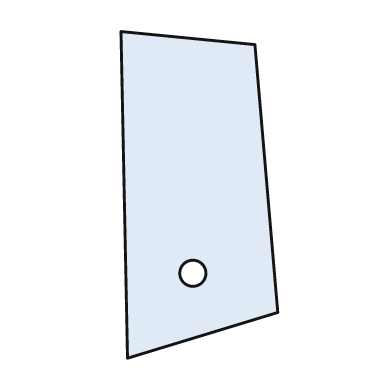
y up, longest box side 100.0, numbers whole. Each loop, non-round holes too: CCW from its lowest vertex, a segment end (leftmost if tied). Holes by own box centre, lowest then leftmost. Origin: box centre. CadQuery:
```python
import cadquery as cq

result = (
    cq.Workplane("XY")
    .moveTo(-22.0, -50.0)
    .lineTo(24.0, -36.0)
    .lineTo(17.0, 46.0)
    .lineTo(-24.0, 50.0)
    .close()
    .moveTo(-2.0, -24.0)
    .circle(4.0)
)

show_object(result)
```